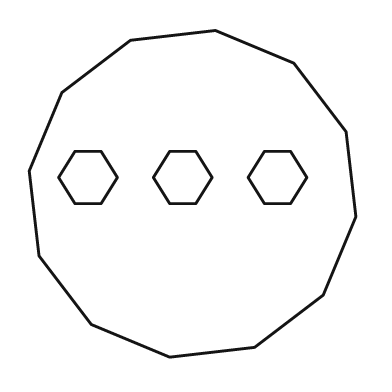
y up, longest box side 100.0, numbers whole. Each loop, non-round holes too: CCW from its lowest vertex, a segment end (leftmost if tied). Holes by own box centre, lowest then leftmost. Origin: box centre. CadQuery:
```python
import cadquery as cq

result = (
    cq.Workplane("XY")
    .moveTo(-7.0, -50.0)
    .lineTo(19.0, -47.0)
    .lineTo(40.0, -31.0)
    .lineTo(50.0, -7.0)
    .lineTo(47.0, 19.0)
    .lineTo(31.0, 40.0)
    .lineTo(7.0, 50.0)
    .lineTo(-19.0, 47.0)
    .lineTo(-40.0, 31.0)
    .lineTo(-50.0, 7.0)
    .lineTo(-47.0, -19.0)
    .lineTo(-31.0, -40.0)
    .close()
    .moveTo(-36.0, -3.0)
    .lineTo(-28.0, -3.0)
    .lineTo(-23.0, 5.0)
    .lineTo(-28.0, 13.0)
    .lineTo(-36.0, 13.0)
    .lineTo(-41.0, 5.0)
    .close()
    .moveTo(-7.0, -3.0)
    .lineTo(1.0, -3.0)
    .lineTo(6.0, 5.0)
    .lineTo(1.0, 13.0)
    .lineTo(-7.0, 13.0)
    .lineTo(-12.0, 5.0)
    .close()
    .moveTo(22.0, -3.0)
    .lineTo(30.0, -3.0)
    .lineTo(35.0, 5.0)
    .lineTo(30.0, 13.0)
    .lineTo(22.0, 13.0)
    .lineTo(17.0, 5.0)
    .close()
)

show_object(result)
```